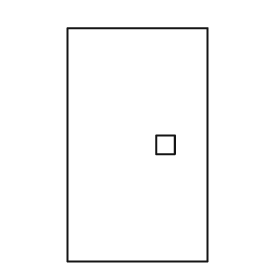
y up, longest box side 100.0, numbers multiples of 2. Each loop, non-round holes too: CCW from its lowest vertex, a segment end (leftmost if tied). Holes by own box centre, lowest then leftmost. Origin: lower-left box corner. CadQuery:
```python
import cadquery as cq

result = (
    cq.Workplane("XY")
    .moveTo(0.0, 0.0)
    .lineTo(60.0, 0.0)
    .lineTo(60.0, 100.0)
    .lineTo(0.0, 100.0)
    .close()
    .moveTo(38.0, 46.0)
    .lineTo(46.0, 46.0)
    .lineTo(46.0, 54.0)
    .lineTo(38.0, 54.0)
    .close()
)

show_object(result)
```